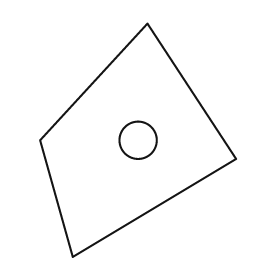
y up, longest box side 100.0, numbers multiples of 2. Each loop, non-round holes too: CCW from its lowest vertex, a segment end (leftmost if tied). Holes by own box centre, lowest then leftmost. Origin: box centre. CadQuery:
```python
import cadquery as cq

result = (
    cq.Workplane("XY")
    .moveTo(-28.0, -50.0)
    .lineTo(42.0, -8.0)
    .lineTo(4.0, 50.0)
    .lineTo(-42.0, 0.0)
    .close()
    .moveTo(0.0, 0.0)
    .circle(8.0)
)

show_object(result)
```